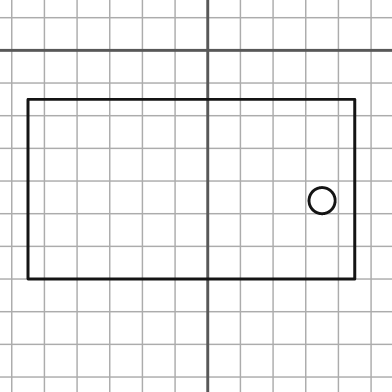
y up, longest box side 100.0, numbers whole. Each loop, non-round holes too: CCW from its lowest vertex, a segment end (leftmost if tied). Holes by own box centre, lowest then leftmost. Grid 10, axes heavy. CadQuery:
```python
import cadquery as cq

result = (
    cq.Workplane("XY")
    .moveTo(-55.0, -70.0)
    .lineTo(45.0, -70.0)
    .lineTo(45.0, -15.0)
    .lineTo(-55.0, -15.0)
    .close()
    .moveTo(35.0, -46.0)
    .circle(4.0)
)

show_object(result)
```